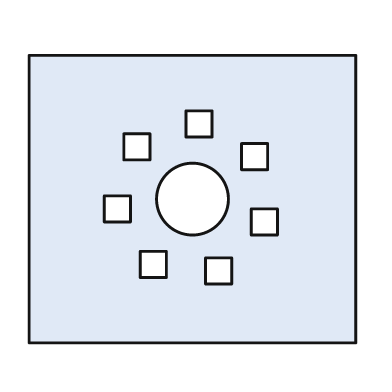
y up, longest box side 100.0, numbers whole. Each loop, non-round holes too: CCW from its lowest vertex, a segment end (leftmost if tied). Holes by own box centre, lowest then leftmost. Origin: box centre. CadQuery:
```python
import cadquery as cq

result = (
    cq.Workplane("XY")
    .moveTo(-50.0, -44.0)
    .lineTo(50.0, -44.0)
    .lineTo(50.0, 44.0)
    .lineTo(-50.0, 44.0)
    .close()
    .moveTo(4.0, -26.0)
    .lineTo(12.0, -26.0)
    .lineTo(12.0, -18.0)
    .lineTo(4.0, -18.0)
    .close()
    .moveTo(-16.0, -24.0)
    .lineTo(-8.0, -24.0)
    .lineTo(-8.0, -16.0)
    .lineTo(-16.0, -16.0)
    .close()
    .moveTo(18.0, -11.0)
    .lineTo(26.0, -11.0)
    .lineTo(26.0, -3.0)
    .lineTo(18.0, -3.0)
    .close()
    .moveTo(-27.0, -7.0)
    .lineTo(-19.0, -7.0)
    .lineTo(-19.0, 1.0)
    .lineTo(-27.0, 1.0)
    .close()
    .moveTo(0.0, 0.0)
    .circle(11.0)
    .moveTo(15.0, 9.0)
    .lineTo(23.0, 9.0)
    .lineTo(23.0, 17.0)
    .lineTo(15.0, 17.0)
    .close()
    .moveTo(-21.0, 12.0)
    .lineTo(-13.0, 12.0)
    .lineTo(-13.0, 20.0)
    .lineTo(-21.0, 20.0)
    .close()
    .moveTo(-2.0, 19.0)
    .lineTo(6.0, 19.0)
    .lineTo(6.0, 27.0)
    .lineTo(-2.0, 27.0)
    .close()
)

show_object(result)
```